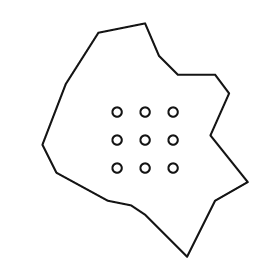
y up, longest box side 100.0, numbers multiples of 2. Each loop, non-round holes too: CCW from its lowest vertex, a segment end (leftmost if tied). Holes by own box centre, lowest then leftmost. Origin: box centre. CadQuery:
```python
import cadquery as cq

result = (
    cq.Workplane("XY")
    .moveTo(18.0, -50.0)
    .lineTo(30.0, -26.0)
    .lineTo(44.0, -18.0)
    .lineTo(28.0, 2.0)
    .lineTo(36.0, 20.0)
    .lineTo(30.0, 28.0)
    .lineTo(14.0, 28.0)
    .lineTo(6.0, 36.0)
    .lineTo(0.0, 50.0)
    .lineTo(-20.0, 46.0)
    .lineTo(-34.0, 24.0)
    .lineTo(-44.0, -2.0)
    .lineTo(-38.0, -14.0)
    .lineTo(-16.0, -26.0)
    .lineTo(-6.0, -28.0)
    .lineTo(0.0, -32.0)
    .close()
    .moveTo(-12.0, -12.0)
    .circle(2.0)
    .moveTo(0.0, -12.0)
    .circle(2.0)
    .moveTo(12.0, -12.0)
    .circle(2.0)
    .moveTo(-12.0, 0.0)
    .circle(2.0)
    .moveTo(0.0, 0.0)
    .circle(2.0)
    .moveTo(12.0, 0.0)
    .circle(2.0)
    .moveTo(-12.0, 12.0)
    .circle(2.0)
    .moveTo(0.0, 12.0)
    .circle(2.0)
    .moveTo(12.0, 12.0)
    .circle(2.0)
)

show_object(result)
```